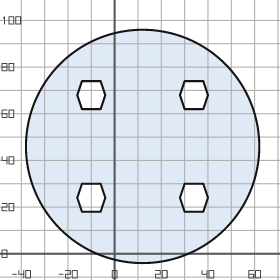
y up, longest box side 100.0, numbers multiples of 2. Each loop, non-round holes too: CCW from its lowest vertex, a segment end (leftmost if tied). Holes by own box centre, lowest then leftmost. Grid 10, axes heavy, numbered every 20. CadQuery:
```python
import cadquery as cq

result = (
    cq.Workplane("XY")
    .moveTo(12.0, 46.0)
    .circle(50.0)
    .moveTo(-14.0, 18.0)
    .lineTo(-6.0, 18.0)
    .lineTo(-4.0, 24.0)
    .lineTo(-6.0, 30.0)
    .lineTo(-14.0, 30.0)
    .lineTo(-16.0, 24.0)
    .close()
    .moveTo(30.0, 18.0)
    .lineTo(38.0, 18.0)
    .lineTo(40.0, 24.0)
    .lineTo(38.0, 30.0)
    .lineTo(30.0, 30.0)
    .lineTo(28.0, 24.0)
    .close()
    .moveTo(-14.0, 62.0)
    .lineTo(-6.0, 62.0)
    .lineTo(-4.0, 68.0)
    .lineTo(-6.0, 74.0)
    .lineTo(-14.0, 74.0)
    .lineTo(-16.0, 68.0)
    .close()
    .moveTo(30.0, 62.0)
    .lineTo(38.0, 62.0)
    .lineTo(40.0, 68.0)
    .lineTo(38.0, 74.0)
    .lineTo(30.0, 74.0)
    .lineTo(28.0, 68.0)
    .close()
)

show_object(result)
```